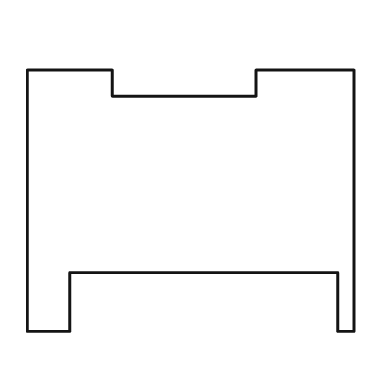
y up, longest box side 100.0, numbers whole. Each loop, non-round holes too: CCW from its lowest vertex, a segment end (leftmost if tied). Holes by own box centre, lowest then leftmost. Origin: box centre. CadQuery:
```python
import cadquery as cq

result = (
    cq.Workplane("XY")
    .moveTo(-50.0, -40.0)
    .lineTo(-37.0, -40.0)
    .lineTo(-37.0, -22.0)
    .lineTo(45.0, -22.0)
    .lineTo(45.0, -40.0)
    .lineTo(50.0, -40.0)
    .lineTo(50.0, 40.0)
    .lineTo(20.0, 40.0)
    .lineTo(20.0, 32.0)
    .lineTo(-24.0, 32.0)
    .lineTo(-24.0, 40.0)
    .lineTo(-50.0, 40.0)
    .close()
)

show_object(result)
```